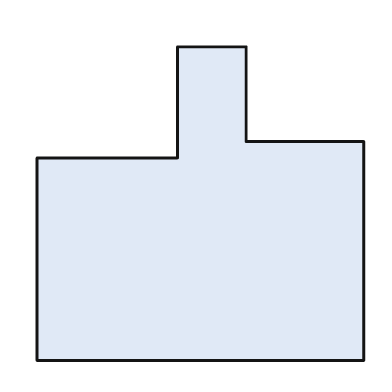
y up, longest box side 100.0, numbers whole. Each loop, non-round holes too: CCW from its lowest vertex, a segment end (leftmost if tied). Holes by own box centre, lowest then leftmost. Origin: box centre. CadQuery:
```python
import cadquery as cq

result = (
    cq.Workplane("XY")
    .moveTo(-50.0, -48.0)
    .lineTo(50.0, -48.0)
    .lineTo(50.0, 19.0)
    .lineTo(14.0, 19.0)
    .lineTo(14.0, 48.0)
    .lineTo(-7.0, 48.0)
    .lineTo(-7.0, 14.0)
    .lineTo(-50.0, 14.0)
    .close()
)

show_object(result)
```